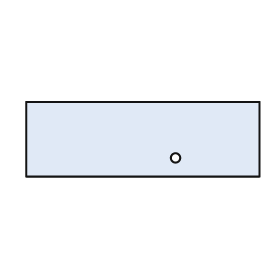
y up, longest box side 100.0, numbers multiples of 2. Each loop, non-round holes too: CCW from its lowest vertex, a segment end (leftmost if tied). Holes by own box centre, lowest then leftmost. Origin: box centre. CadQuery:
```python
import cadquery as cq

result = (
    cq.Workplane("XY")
    .moveTo(-50.0, -16.0)
    .lineTo(50.0, -16.0)
    .lineTo(50.0, 16.0)
    .lineTo(-50.0, 16.0)
    .close()
    .moveTo(14.0, -8.0)
    .circle(2.0)
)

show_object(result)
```